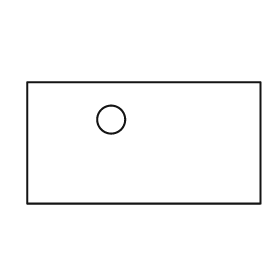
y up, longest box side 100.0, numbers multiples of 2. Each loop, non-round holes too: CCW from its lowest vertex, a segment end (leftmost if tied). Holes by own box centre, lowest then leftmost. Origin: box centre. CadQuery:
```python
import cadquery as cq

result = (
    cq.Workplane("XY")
    .moveTo(-50.0, -26.0)
    .lineTo(50.0, -26.0)
    .lineTo(50.0, 26.0)
    .lineTo(-50.0, 26.0)
    .close()
    .moveTo(-14.0, 10.0)
    .circle(6.0)
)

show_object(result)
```